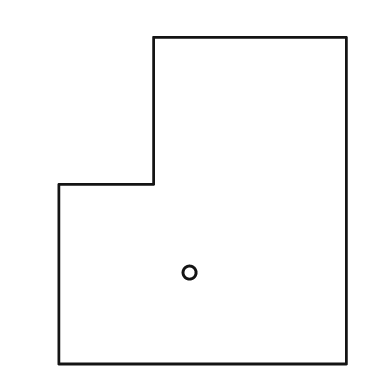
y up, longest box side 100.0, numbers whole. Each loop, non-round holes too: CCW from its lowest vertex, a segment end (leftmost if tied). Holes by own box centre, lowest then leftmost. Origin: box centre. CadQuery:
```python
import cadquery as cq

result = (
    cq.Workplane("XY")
    .moveTo(-44.0, -50.0)
    .lineTo(44.0, -50.0)
    .lineTo(44.0, 50.0)
    .lineTo(-15.0, 50.0)
    .lineTo(-15.0, 5.0)
    .lineTo(-44.0, 5.0)
    .close()
    .moveTo(-4.0, -22.0)
    .circle(2.0)
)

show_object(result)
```